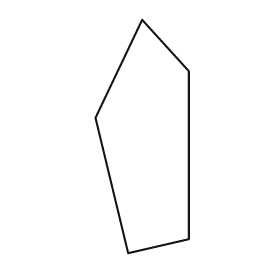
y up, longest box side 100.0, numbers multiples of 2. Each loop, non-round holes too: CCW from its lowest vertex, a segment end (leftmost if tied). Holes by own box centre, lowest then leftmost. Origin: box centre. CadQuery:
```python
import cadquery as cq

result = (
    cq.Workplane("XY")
    .moveTo(-6.0, -50.0)
    .lineTo(20.0, -44.0)
    .lineTo(20.0, 28.0)
    .lineTo(0.0, 50.0)
    .lineTo(-20.0, 8.0)
    .close()
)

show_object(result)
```